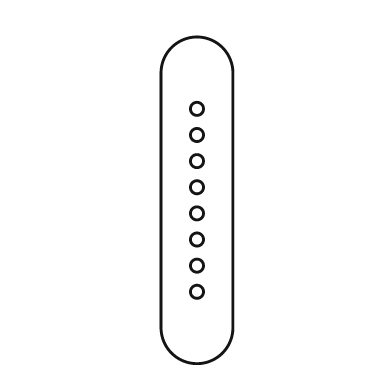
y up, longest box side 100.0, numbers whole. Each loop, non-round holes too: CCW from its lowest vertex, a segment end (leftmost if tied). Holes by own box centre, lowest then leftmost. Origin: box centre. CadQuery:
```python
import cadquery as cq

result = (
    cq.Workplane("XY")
    .moveTo(-11.0, -39.0)
    .threePointArc((0.0, -50.0), (11.0, -39.0))
    .lineTo(11.0, 39.0)
    .threePointArc((0.0, 50.0), (-11.0, 39.0))
    .close()
    .moveTo(0.0, -28.0)
    .circle(2.0)
    .moveTo(0.0, -20.0)
    .circle(2.0)
    .moveTo(0.0, -12.0)
    .circle(2.0)
    .moveTo(0.0, -4.0)
    .circle(2.0)
    .moveTo(0.0, 4.0)
    .circle(2.0)
    .moveTo(0.0, 12.0)
    .circle(2.0)
    .moveTo(0.0, 20.0)
    .circle(2.0)
    .moveTo(0.0, 28.0)
    .circle(2.0)
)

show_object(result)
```